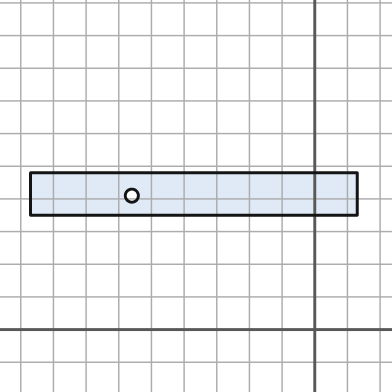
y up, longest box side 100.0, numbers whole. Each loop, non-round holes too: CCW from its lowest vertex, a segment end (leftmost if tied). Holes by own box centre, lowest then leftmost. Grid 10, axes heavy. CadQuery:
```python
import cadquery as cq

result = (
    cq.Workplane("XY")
    .moveTo(-87.0, 35.0)
    .lineTo(13.0, 35.0)
    .lineTo(13.0, 48.0)
    .lineTo(-87.0, 48.0)
    .close()
    .moveTo(-56.0, 41.0)
    .circle(2.0)
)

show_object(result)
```